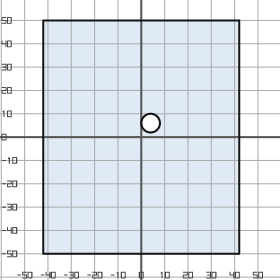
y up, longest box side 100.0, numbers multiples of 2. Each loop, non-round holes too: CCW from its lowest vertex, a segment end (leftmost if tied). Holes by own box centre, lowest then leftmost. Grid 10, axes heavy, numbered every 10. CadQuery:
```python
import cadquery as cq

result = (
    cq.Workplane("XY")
    .moveTo(-42.0, -50.0)
    .lineTo(42.0, -50.0)
    .lineTo(42.0, 50.0)
    .lineTo(-42.0, 50.0)
    .close()
    .moveTo(4.0, 6.0)
    .circle(4.0)
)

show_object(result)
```